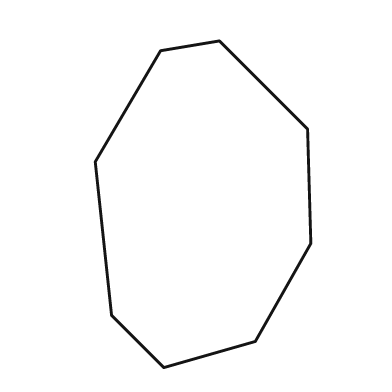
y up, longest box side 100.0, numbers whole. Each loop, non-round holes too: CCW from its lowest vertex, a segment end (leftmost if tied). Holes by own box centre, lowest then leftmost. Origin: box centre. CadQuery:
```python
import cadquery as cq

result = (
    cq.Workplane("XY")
    .moveTo(-12.0, -50.0)
    .lineTo(16.0, -42.0)
    .lineTo(33.0, -12.0)
    .lineTo(32.0, 23.0)
    .lineTo(5.0, 50.0)
    .lineTo(-13.0, 47.0)
    .lineTo(-33.0, 13.0)
    .lineTo(-28.0, -34.0)
    .close()
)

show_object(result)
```